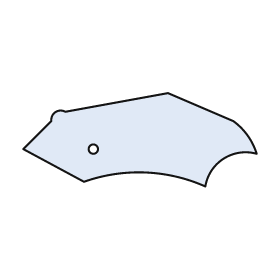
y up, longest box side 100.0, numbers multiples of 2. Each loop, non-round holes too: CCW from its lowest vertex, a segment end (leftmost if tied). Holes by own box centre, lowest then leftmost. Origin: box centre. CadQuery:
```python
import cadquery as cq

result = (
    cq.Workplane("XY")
    .moveTo(28.0, -20.0)
    .threePointArc((36.0, -8.0), (50.0, -6.0))
    .threePointArc((46.0, 2.0), (40.0, 8.0))
    .lineTo(12.0, 20.0)
    .lineTo(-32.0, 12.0)
    .threePointArc((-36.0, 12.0), (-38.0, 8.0))
    .lineTo(-50.0, -4.0)
    .lineTo(-24.0, -18.0)
    .threePointArc((2.0, -14.0), (28.0, -20.0))
    .close()
    .moveTo(-20.0, -4.0)
    .circle(2.0)
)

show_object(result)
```